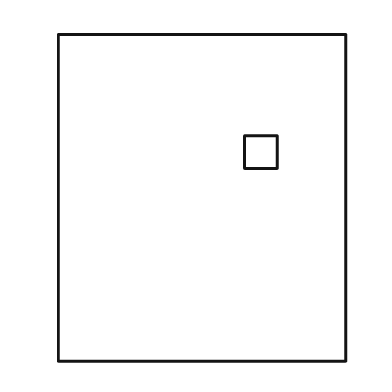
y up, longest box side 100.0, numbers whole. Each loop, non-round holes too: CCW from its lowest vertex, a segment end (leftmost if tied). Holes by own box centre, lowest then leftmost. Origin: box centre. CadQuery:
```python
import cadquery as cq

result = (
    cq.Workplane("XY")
    .moveTo(-44.0, -50.0)
    .lineTo(44.0, -50.0)
    .lineTo(44.0, 50.0)
    .lineTo(-44.0, 50.0)
    .close()
    .moveTo(13.0, 9.0)
    .lineTo(23.0, 9.0)
    .lineTo(23.0, 19.0)
    .lineTo(13.0, 19.0)
    .close()
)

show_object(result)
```